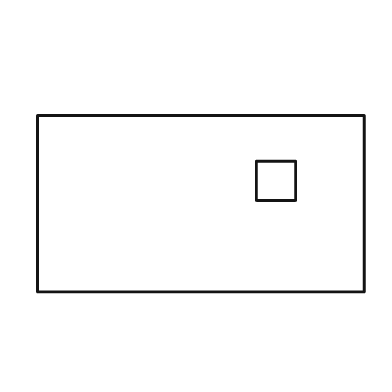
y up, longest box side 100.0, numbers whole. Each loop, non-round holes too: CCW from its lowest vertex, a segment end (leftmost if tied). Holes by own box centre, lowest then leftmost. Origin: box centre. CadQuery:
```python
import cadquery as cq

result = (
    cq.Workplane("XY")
    .moveTo(-50.0, -27.0)
    .lineTo(50.0, -27.0)
    .lineTo(50.0, 27.0)
    .lineTo(-50.0, 27.0)
    .close()
    .moveTo(17.0, 1.0)
    .lineTo(29.0, 1.0)
    .lineTo(29.0, 13.0)
    .lineTo(17.0, 13.0)
    .close()
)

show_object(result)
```